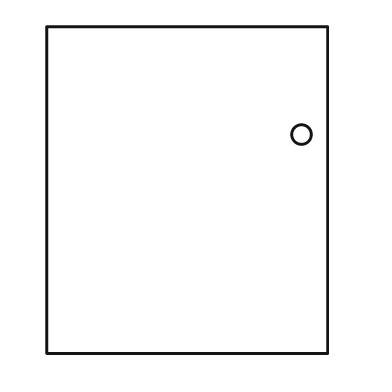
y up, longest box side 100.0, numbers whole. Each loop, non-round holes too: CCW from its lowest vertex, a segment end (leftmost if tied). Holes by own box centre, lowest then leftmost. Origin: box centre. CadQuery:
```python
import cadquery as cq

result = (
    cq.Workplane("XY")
    .moveTo(-43.0, -50.0)
    .lineTo(43.0, -50.0)
    .lineTo(43.0, 50.0)
    .lineTo(-43.0, 50.0)
    .close()
    .moveTo(35.0, 17.0)
    .circle(3.0)
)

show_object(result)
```